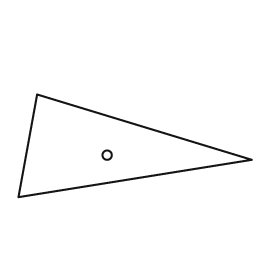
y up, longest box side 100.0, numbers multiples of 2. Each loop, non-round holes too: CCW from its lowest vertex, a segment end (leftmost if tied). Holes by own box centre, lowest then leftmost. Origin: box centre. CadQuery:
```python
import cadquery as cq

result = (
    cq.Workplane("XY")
    .moveTo(-50.0, -22.0)
    .lineTo(50.0, -6.0)
    .lineTo(-42.0, 22.0)
    .close()
    .moveTo(-12.0, -4.0)
    .circle(2.0)
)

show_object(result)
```